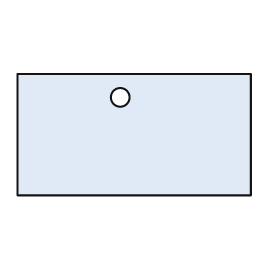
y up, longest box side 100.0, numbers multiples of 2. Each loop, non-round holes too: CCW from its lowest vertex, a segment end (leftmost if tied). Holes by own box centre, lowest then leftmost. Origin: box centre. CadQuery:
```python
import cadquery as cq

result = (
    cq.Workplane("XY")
    .moveTo(-50.0, -26.0)
    .lineTo(50.0, -26.0)
    .lineTo(50.0, 26.0)
    .lineTo(-50.0, 26.0)
    .close()
    .moveTo(-6.0, 16.0)
    .circle(4.0)
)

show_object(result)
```